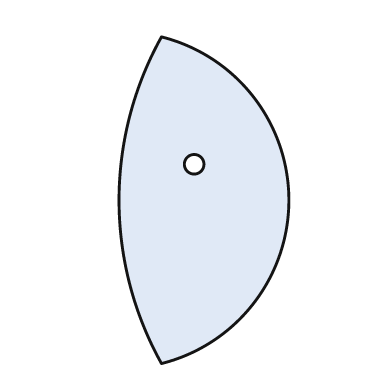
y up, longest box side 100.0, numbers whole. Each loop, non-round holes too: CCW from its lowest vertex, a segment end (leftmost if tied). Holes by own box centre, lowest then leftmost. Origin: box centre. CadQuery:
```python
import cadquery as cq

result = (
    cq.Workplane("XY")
    .moveTo(-13.0, -50.0)
    .threePointArc((26.0, 0.0), (-13.0, 50.0))
    .threePointArc((-26.0, 0.0), (-13.0, -50.0))
    .close()
    .moveTo(-3.0, 11.0)
    .circle(3.0)
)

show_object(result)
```